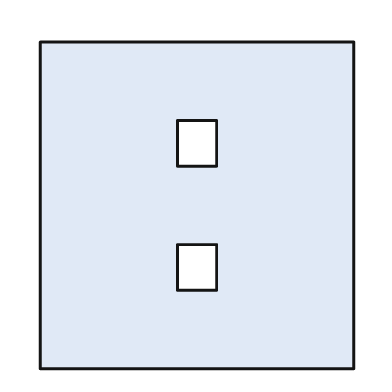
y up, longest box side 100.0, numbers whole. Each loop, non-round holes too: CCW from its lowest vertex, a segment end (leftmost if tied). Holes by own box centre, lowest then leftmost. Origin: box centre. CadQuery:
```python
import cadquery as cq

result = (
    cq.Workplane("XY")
    .moveTo(-48.0, -50.0)
    .lineTo(48.0, -50.0)
    .lineTo(48.0, 50.0)
    .lineTo(-48.0, 50.0)
    .close()
    .moveTo(-6.0, -26.0)
    .lineTo(6.0, -26.0)
    .lineTo(6.0, -12.0)
    .lineTo(-6.0, -12.0)
    .close()
    .moveTo(-6.0, 12.0)
    .lineTo(6.0, 12.0)
    .lineTo(6.0, 26.0)
    .lineTo(-6.0, 26.0)
    .close()
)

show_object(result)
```